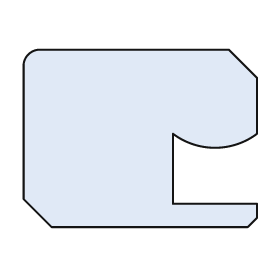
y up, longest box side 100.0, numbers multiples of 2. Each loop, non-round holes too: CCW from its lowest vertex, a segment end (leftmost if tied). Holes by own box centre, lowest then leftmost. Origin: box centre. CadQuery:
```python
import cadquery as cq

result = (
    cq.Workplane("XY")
    .moveTo(-38.0, -38.0)
    .lineTo(46.0, -38.0)
    .lineTo(50.0, -34.0)
    .lineTo(50.0, -28.0)
    .lineTo(14.0, -28.0)
    .lineTo(14.0, 2.0)
    .threePointArc((32.0, -4.0), (50.0, 2.0))
    .lineTo(50.0, 26.0)
    .lineTo(38.0, 38.0)
    .lineTo(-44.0, 38.0)
    .threePointArc((-48.0, 36.0), (-50.0, 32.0))
    .lineTo(-50.0, -26.0)
    .close()
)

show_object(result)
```